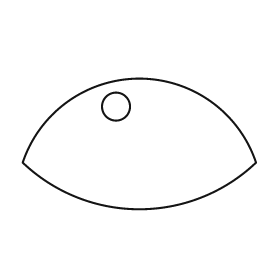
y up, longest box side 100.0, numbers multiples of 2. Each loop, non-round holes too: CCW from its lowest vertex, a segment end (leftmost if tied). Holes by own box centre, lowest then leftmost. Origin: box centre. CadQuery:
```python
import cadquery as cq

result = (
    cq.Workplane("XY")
    .moveTo(-50.0, -8.0)
    .threePointArc((0.0, -28.0), (50.0, -8.0))
    .threePointArc((0.0, 28.0), (-50.0, -8.0))
    .close()
    .moveTo(-10.0, 16.0)
    .circle(6.0)
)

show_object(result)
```